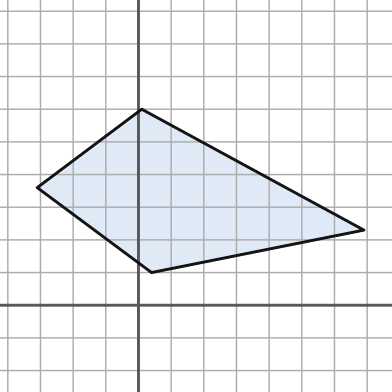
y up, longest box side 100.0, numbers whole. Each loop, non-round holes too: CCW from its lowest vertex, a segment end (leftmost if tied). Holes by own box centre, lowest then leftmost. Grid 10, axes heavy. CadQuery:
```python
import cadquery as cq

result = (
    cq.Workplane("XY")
    .moveTo(4.0, 10.0)
    .lineTo(69.0, 23.0)
    .lineTo(1.0, 60.0)
    .lineTo(-31.0, 36.0)
    .close()
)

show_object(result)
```